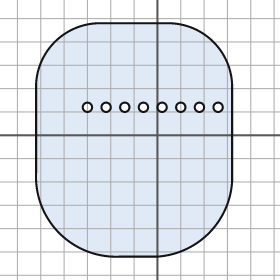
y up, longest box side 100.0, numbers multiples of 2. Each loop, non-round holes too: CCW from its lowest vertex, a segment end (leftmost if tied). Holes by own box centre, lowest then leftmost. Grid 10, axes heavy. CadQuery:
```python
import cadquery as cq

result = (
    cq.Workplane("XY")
    .moveTo(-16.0, -52.0)
    .lineTo(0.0, -52.0)
    .threePointArc((22.0, -42.0), (32.0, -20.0))
    .lineTo(32.0, 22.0)
    .threePointArc((24.0, 40.0), (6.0, 48.0))
    .lineTo(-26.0, 48.0)
    .threePointArc((-44.0, 40.0), (-52.0, 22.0))
    .lineTo(-52.0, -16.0)
    .threePointArc((-42.0, -42.0), (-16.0, -52.0))
    .close()
    .moveTo(-30.0, 12.0)
    .circle(2.0)
    .moveTo(-22.0, 12.0)
    .circle(2.0)
    .moveTo(-14.0, 12.0)
    .circle(2.0)
    .moveTo(-6.0, 12.0)
    .circle(2.0)
    .moveTo(2.0, 12.0)
    .circle(2.0)
    .moveTo(10.0, 12.0)
    .circle(2.0)
    .moveTo(18.0, 12.0)
    .circle(2.0)
    .moveTo(26.0, 12.0)
    .circle(2.0)
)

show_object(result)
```